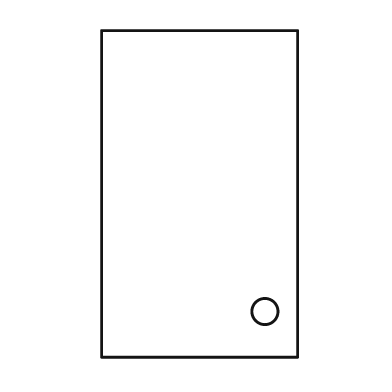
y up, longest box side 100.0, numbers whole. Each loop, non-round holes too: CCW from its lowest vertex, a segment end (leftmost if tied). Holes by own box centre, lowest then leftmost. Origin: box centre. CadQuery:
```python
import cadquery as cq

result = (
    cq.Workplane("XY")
    .moveTo(-30.0, -50.0)
    .lineTo(30.0, -50.0)
    .lineTo(30.0, 50.0)
    .lineTo(-30.0, 50.0)
    .close()
    .moveTo(20.0, -36.0)
    .circle(4.0)
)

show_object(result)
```